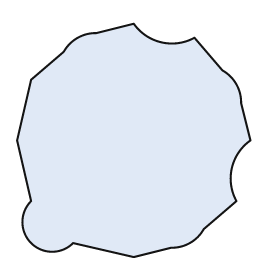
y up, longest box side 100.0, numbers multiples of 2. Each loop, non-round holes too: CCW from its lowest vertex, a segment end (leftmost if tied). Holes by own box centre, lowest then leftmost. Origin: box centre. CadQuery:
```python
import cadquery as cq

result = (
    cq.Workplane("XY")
    .moveTo(0.0, -50.0)
    .lineTo(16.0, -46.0)
    .threePointArc((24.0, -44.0), (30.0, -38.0))
    .lineTo(44.0, -26.0)
    .threePointArc((42.0, -12.0), (50.0, 0.0))
    .lineTo(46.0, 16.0)
    .threePointArc((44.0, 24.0), (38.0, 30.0))
    .lineTo(26.0, 44.0)
    .threePointArc((12.0, 42.0), (0.0, 50.0))
    .lineTo(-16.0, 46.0)
    .threePointArc((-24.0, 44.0), (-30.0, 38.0))
    .lineTo(-44.0, 26.0)
    .lineTo(-50.0, 0.0)
    .lineTo(-44.0, -26.0)
    .threePointArc((-44.0, -44.0), (-26.0, -44.0))
    .close()
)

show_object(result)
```